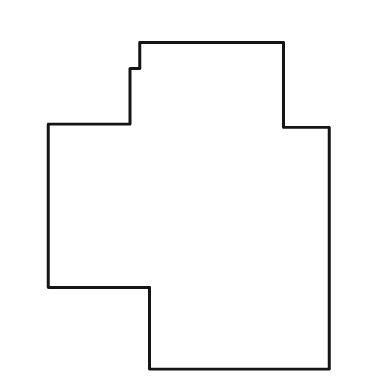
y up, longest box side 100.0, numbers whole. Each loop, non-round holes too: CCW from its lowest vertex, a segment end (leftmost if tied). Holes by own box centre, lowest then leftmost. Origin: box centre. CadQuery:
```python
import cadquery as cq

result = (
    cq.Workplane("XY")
    .moveTo(-12.0, -50.0)
    .lineTo(43.0, -50.0)
    .lineTo(43.0, 24.0)
    .lineTo(29.0, 24.0)
    .lineTo(29.0, 50.0)
    .lineTo(-15.0, 50.0)
    .lineTo(-15.0, 42.0)
    .lineTo(-18.0, 42.0)
    .lineTo(-18.0, 25.0)
    .lineTo(-43.0, 25.0)
    .lineTo(-43.0, -25.0)
    .lineTo(-12.0, -25.0)
    .close()
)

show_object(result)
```